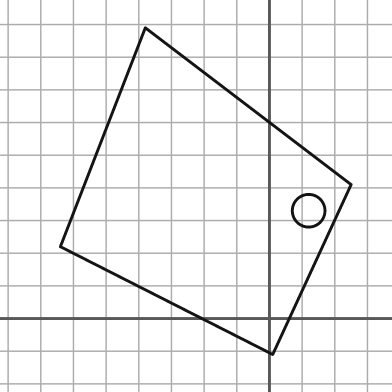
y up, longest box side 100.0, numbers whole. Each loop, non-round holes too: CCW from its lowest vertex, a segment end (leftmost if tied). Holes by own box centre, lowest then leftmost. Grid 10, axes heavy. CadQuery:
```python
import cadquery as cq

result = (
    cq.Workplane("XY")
    .moveTo(1.0, -11.0)
    .lineTo(25.0, 41.0)
    .lineTo(-38.0, 89.0)
    .lineTo(-64.0, 22.0)
    .close()
    .moveTo(12.0, 33.0)
    .circle(5.0)
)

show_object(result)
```